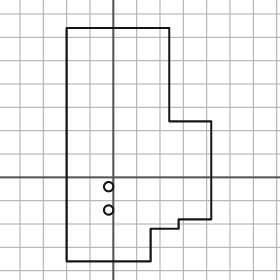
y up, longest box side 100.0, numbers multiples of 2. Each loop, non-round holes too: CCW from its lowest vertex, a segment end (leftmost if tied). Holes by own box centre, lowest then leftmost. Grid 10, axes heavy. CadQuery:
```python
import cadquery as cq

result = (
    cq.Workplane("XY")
    .moveTo(-20.0, -36.0)
    .lineTo(16.0, -36.0)
    .lineTo(16.0, -22.0)
    .lineTo(28.0, -22.0)
    .lineTo(28.0, -18.0)
    .lineTo(42.0, -18.0)
    .lineTo(42.0, 24.0)
    .lineTo(24.0, 24.0)
    .lineTo(24.0, 64.0)
    .lineTo(-20.0, 64.0)
    .close()
    .moveTo(-2.0, -14.0)
    .circle(2.0)
    .moveTo(-2.0, -4.0)
    .circle(2.0)
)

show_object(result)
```